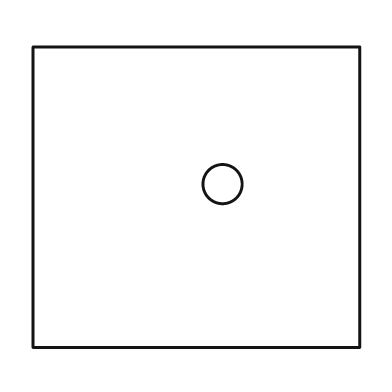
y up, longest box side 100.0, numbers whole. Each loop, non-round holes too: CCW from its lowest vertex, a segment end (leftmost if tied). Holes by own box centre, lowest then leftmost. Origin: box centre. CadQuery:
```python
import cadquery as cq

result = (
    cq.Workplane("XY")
    .moveTo(-50.0, -46.0)
    .lineTo(50.0, -46.0)
    .lineTo(50.0, 46.0)
    .lineTo(-50.0, 46.0)
    .close()
    .moveTo(8.0, 4.0)
    .circle(6.0)
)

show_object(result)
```